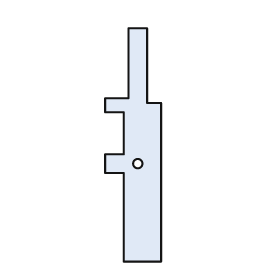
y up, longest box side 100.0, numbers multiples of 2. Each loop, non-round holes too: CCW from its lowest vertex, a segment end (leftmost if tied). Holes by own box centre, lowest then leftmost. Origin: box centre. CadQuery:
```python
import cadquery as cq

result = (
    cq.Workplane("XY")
    .moveTo(-4.0, -50.0)
    .lineTo(12.0, -50.0)
    .lineTo(12.0, 18.0)
    .lineTo(6.0, 18.0)
    .lineTo(6.0, 50.0)
    .lineTo(-2.0, 50.0)
    .lineTo(-2.0, 20.0)
    .lineTo(-12.0, 20.0)
    .lineTo(-12.0, 14.0)
    .lineTo(-4.0, 14.0)
    .lineTo(-4.0, -4.0)
    .lineTo(-12.0, -4.0)
    .lineTo(-12.0, -12.0)
    .lineTo(-4.0, -12.0)
    .close()
    .moveTo(2.0, -8.0)
    .circle(2.0)
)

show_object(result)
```